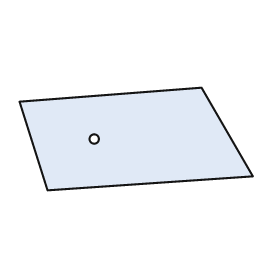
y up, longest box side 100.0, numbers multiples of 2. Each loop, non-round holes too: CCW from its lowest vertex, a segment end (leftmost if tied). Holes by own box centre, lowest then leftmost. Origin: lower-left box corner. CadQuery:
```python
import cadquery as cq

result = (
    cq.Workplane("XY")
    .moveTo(12.0, 0.0)
    .lineTo(100.0, 6.0)
    .lineTo(78.0, 44.0)
    .lineTo(0.0, 38.0)
    .close()
    .moveTo(32.0, 22.0)
    .circle(2.0)
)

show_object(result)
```